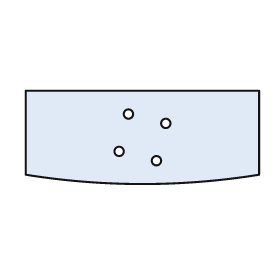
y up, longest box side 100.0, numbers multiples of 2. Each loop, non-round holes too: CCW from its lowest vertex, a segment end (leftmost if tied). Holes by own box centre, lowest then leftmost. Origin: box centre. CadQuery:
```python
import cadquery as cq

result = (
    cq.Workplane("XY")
    .moveTo(-50.0, -16.0)
    .threePointArc((0.0, -20.0), (50.0, -16.0))
    .lineTo(50.0, 20.0)
    .lineTo(-50.0, 20.0)
    .close()
    .moveTo(6.0, -10.0)
    .circle(2.0)
    .moveTo(-10.0, -6.0)
    .circle(2.0)
    .moveTo(10.0, 6.0)
    .circle(2.0)
    .moveTo(-6.0, 10.0)
    .circle(2.0)
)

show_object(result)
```